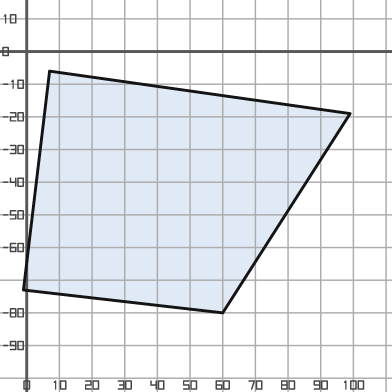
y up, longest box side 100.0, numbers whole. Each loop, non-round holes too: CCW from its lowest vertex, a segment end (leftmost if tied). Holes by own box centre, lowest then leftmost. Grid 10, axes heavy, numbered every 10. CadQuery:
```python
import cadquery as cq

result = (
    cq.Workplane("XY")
    .moveTo(60.0, -80.0)
    .lineTo(99.0, -19.0)
    .lineTo(7.0, -6.0)
    .lineTo(-1.0, -73.0)
    .close()
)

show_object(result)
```